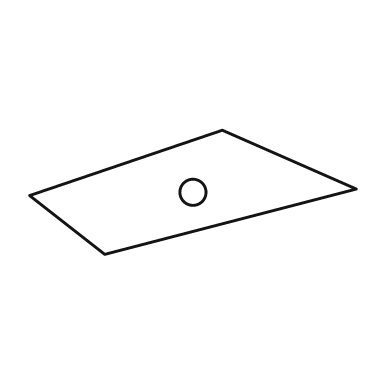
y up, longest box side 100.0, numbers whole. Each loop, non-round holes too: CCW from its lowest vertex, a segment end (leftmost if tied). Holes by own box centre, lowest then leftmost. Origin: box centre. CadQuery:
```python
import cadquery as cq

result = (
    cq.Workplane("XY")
    .moveTo(-27.0, -19.0)
    .lineTo(50.0, 1.0)
    .lineTo(9.0, 19.0)
    .lineTo(-50.0, -1.0)
    .close()
    .moveTo(0.0, 0.0)
    .circle(4.0)
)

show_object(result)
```